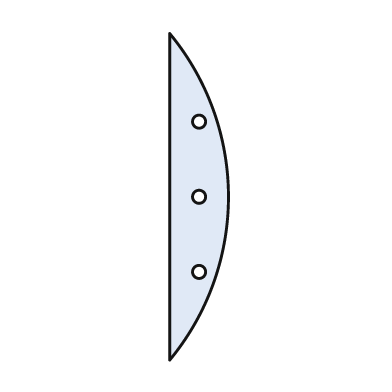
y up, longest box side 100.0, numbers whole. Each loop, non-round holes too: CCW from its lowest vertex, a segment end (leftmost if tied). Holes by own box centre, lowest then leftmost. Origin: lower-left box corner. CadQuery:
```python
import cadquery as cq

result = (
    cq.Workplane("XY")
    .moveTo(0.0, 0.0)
    .threePointArc((18.0, 50.0), (0.0, 100.0))
    .close()
    .moveTo(9.0, 27.0)
    .circle(2.0)
    .moveTo(9.0, 50.0)
    .circle(2.0)
    .moveTo(9.0, 73.0)
    .circle(2.0)
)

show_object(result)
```